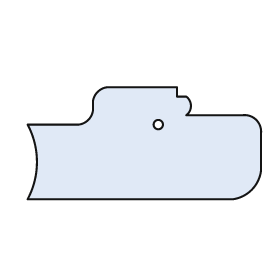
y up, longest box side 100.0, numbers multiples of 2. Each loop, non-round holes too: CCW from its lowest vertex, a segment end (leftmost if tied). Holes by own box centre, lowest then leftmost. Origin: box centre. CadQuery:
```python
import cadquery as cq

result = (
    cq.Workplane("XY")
    .moveTo(-50.0, -24.0)
    .lineTo(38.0, -24.0)
    .threePointArc((46.0, -20.0), (50.0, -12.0))
    .lineTo(50.0, 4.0)
    .threePointArc((48.0, 10.0), (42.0, 12.0))
    .lineTo(18.0, 12.0)
    .threePointArc((20.0, 16.0), (18.0, 20.0))
    .lineTo(14.0, 20.0)
    .lineTo(14.0, 24.0)
    .lineTo(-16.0, 24.0)
    .threePointArc((-20.0, 22.0), (-22.0, 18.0))
    .lineTo(-22.0, 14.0)
    .threePointArc((-24.0, 10.0), (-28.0, 8.0))
    .lineTo(-50.0, 8.0)
    .threePointArc((-46.0, -8.0), (-50.0, -24.0))
    .close()
    .moveTo(6.0, 8.0)
    .circle(2.0)
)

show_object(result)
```